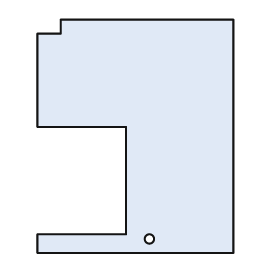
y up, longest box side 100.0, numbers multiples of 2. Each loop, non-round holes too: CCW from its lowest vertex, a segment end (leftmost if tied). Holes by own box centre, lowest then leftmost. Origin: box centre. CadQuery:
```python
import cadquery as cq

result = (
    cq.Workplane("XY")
    .moveTo(-42.0, -50.0)
    .lineTo(42.0, -50.0)
    .lineTo(42.0, 50.0)
    .lineTo(-32.0, 50.0)
    .lineTo(-32.0, 44.0)
    .lineTo(-42.0, 44.0)
    .lineTo(-42.0, 4.0)
    .lineTo(-4.0, 4.0)
    .lineTo(-4.0, -42.0)
    .lineTo(-42.0, -42.0)
    .close()
    .moveTo(6.0, -44.0)
    .circle(2.0)
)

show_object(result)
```